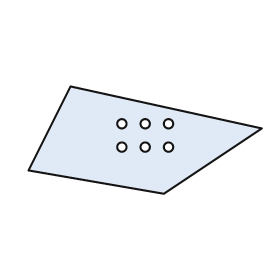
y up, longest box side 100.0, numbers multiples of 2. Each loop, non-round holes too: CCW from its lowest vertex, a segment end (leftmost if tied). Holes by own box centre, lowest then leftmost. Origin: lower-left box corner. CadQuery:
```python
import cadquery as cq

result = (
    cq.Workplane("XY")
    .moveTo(58.0, 0.0)
    .lineTo(100.0, 28.0)
    .lineTo(18.0, 46.0)
    .lineTo(0.0, 10.0)
    .close()
    .moveTo(40.0, 20.0)
    .circle(2.0)
    .moveTo(50.0, 20.0)
    .circle(2.0)
    .moveTo(60.0, 20.0)
    .circle(2.0)
    .moveTo(40.0, 30.0)
    .circle(2.0)
    .moveTo(50.0, 30.0)
    .circle(2.0)
    .moveTo(60.0, 30.0)
    .circle(2.0)
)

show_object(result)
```